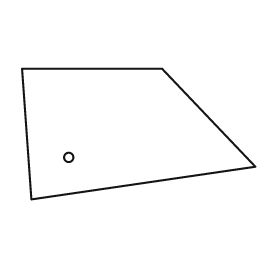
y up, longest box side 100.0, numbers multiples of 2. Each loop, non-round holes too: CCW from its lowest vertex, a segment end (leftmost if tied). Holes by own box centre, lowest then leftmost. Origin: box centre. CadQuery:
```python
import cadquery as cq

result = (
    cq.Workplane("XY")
    .moveTo(-46.0, -28.0)
    .lineTo(50.0, -14.0)
    .lineTo(10.0, 28.0)
    .lineTo(-50.0, 28.0)
    .close()
    .moveTo(-30.0, -10.0)
    .circle(2.0)
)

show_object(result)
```